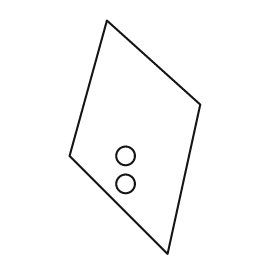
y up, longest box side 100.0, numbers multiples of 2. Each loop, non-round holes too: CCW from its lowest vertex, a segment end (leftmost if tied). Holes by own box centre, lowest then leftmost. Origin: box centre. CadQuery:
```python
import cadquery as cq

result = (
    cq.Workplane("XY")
    .moveTo(14.0, -50.0)
    .lineTo(28.0, 14.0)
    .lineTo(-12.0, 50.0)
    .lineTo(-28.0, -8.0)
    .close()
    .moveTo(-4.0, -20.0)
    .circle(4.0)
    .moveTo(-4.0, -8.0)
    .circle(4.0)
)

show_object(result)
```